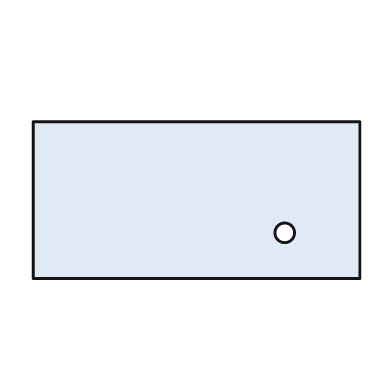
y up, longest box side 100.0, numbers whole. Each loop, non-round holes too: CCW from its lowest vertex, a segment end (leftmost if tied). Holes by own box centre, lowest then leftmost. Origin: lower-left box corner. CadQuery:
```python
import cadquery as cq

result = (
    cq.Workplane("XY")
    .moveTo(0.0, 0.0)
    .lineTo(100.0, 0.0)
    .lineTo(100.0, 48.0)
    .lineTo(0.0, 48.0)
    .close()
    .moveTo(77.0, 14.0)
    .circle(3.0)
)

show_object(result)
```